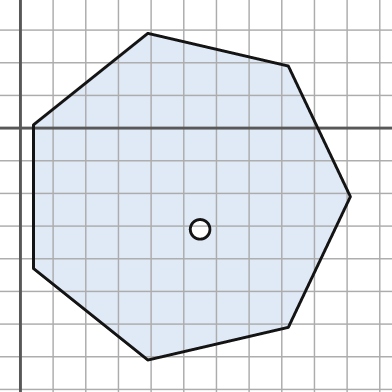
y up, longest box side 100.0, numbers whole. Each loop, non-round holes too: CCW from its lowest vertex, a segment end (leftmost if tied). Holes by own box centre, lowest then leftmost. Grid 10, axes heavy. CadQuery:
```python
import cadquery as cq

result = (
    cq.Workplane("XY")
    .moveTo(39.0, -71.0)
    .lineTo(82.0, -61.0)
    .lineTo(101.0, -21.0)
    .lineTo(82.0, 19.0)
    .lineTo(39.0, 29.0)
    .lineTo(4.0, 1.0)
    .lineTo(4.0, -43.0)
    .close()
    .moveTo(55.0, -31.0)
    .circle(3.0)
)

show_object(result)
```